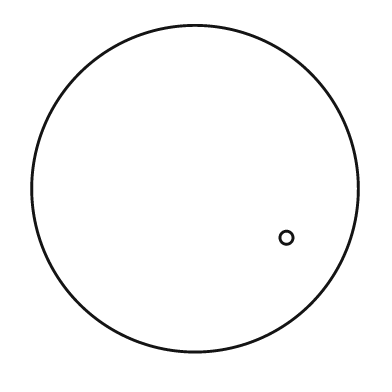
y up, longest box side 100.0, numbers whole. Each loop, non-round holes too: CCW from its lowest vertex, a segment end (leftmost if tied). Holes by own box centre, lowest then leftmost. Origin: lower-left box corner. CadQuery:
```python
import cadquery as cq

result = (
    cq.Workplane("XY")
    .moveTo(50.0, 50.0)
    .circle(50.0)
    .moveTo(78.0, 35.0)
    .circle(2.0)
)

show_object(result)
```